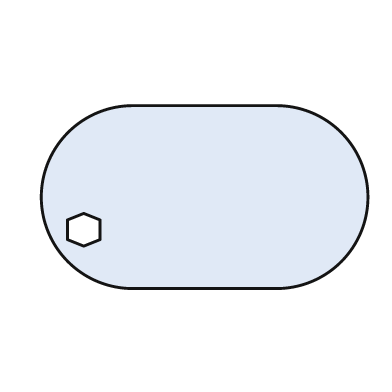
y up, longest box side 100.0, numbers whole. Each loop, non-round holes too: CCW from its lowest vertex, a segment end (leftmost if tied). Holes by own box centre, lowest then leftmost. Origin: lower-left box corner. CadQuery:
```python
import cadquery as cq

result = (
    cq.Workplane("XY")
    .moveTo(28.0, 0.0)
    .lineTo(72.0, 0.0)
    .threePointArc((100.0, 28.0), (72.0, 56.0))
    .lineTo(28.0, 56.0)
    .threePointArc((0.0, 28.0), (28.0, 0.0))
    .close()
    .moveTo(13.0, 13.0)
    .lineTo(18.0, 15.0)
    .lineTo(18.0, 21.0)
    .lineTo(13.0, 23.0)
    .lineTo(8.0, 21.0)
    .lineTo(8.0, 15.0)
    .close()
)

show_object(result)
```